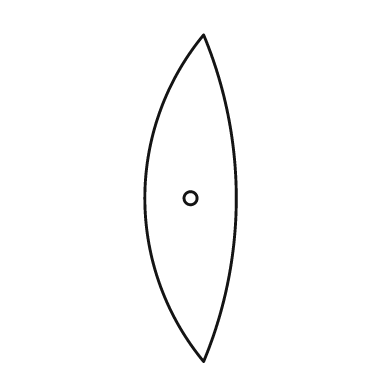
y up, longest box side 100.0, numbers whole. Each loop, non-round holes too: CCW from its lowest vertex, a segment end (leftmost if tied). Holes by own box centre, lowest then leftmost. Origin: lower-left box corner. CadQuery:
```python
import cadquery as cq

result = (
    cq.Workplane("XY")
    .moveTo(18.0, 0.0)
    .threePointArc((28.0, 50.0), (18.0, 100.0))
    .threePointArc((0.0, 50.0), (18.0, 0.0))
    .close()
    .moveTo(14.0, 50.0)
    .circle(2.0)
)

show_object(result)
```